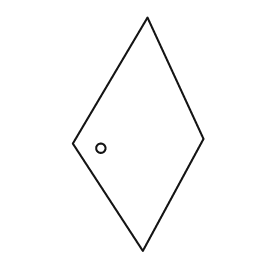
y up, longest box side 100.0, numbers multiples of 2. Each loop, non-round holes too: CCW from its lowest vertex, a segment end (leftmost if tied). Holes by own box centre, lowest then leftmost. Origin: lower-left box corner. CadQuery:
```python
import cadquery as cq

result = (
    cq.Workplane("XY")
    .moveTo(30.0, 0.0)
    .lineTo(56.0, 48.0)
    .lineTo(32.0, 100.0)
    .lineTo(0.0, 46.0)
    .close()
    .moveTo(12.0, 44.0)
    .circle(2.0)
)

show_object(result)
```